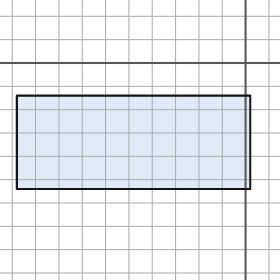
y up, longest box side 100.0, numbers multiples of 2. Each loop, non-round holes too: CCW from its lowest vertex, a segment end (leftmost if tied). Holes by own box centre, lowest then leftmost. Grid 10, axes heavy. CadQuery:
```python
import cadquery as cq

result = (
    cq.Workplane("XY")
    .moveTo(-98.0, -54.0)
    .lineTo(2.0, -54.0)
    .lineTo(2.0, -14.0)
    .lineTo(-98.0, -14.0)
    .close()
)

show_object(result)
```